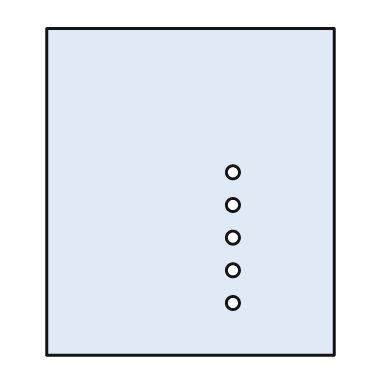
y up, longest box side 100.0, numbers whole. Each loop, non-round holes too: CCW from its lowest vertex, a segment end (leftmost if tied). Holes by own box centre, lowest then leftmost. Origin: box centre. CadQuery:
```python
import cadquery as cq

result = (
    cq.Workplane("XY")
    .moveTo(-44.0, -50.0)
    .lineTo(44.0, -50.0)
    .lineTo(44.0, 50.0)
    .lineTo(-44.0, 50.0)
    .close()
    .moveTo(13.0, -34.0)
    .circle(2.0)
    .moveTo(13.0, -24.0)
    .circle(2.0)
    .moveTo(13.0, -14.0)
    .circle(2.0)
    .moveTo(13.0, -4.0)
    .circle(2.0)
    .moveTo(13.0, 6.0)
    .circle(2.0)
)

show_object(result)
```